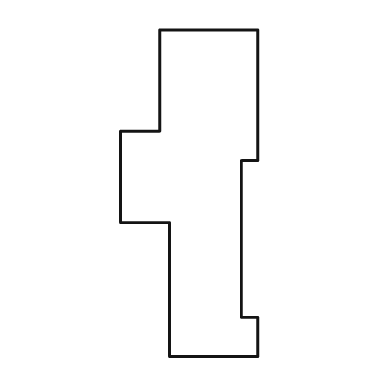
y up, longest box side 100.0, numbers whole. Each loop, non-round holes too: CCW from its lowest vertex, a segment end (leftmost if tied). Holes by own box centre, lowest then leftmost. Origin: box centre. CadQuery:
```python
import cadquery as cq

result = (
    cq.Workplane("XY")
    .moveTo(-6.0, -50.0)
    .lineTo(21.0, -50.0)
    .lineTo(21.0, -38.0)
    .lineTo(16.0, -38.0)
    .lineTo(16.0, 10.0)
    .lineTo(21.0, 10.0)
    .lineTo(21.0, 50.0)
    .lineTo(-9.0, 50.0)
    .lineTo(-9.0, 19.0)
    .lineTo(-21.0, 19.0)
    .lineTo(-21.0, -9.0)
    .lineTo(-6.0, -9.0)
    .close()
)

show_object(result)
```